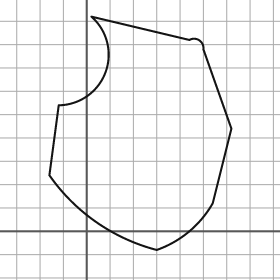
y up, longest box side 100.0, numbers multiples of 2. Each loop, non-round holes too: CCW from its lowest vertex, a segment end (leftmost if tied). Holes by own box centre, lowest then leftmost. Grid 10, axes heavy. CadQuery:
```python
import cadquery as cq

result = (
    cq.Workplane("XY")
    .moveTo(30.0, -8.0)
    .threePointArc((44.0, 0.0), (54.0, 12.0))
    .lineTo(62.0, 44.0)
    .lineTo(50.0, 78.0)
    .threePointArc((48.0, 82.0), (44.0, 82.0))
    .lineTo(2.0, 92.0)
    .threePointArc((8.0, 68.0), (-12.0, 54.0))
    .lineTo(-16.0, 24.0)
    .threePointArc((4.0, 4.0), (30.0, -8.0))
    .close()
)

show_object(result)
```